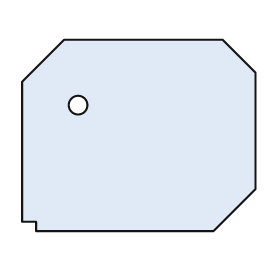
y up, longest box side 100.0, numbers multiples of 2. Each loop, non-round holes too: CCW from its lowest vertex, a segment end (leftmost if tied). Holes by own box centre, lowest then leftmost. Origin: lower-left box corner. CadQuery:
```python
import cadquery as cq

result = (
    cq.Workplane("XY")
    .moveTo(6.0, 0.0)
    .lineTo(82.0, 0.0)
    .lineTo(100.0, 18.0)
    .lineTo(100.0, 68.0)
    .lineTo(86.0, 82.0)
    .lineTo(18.0, 82.0)
    .lineTo(0.0, 64.0)
    .lineTo(0.0, 4.0)
    .lineTo(6.0, 4.0)
    .close()
    .moveTo(24.0, 54.0)
    .circle(4.0)
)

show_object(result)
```